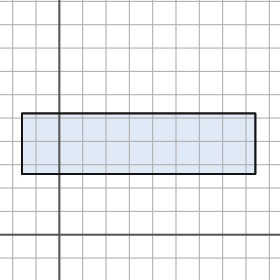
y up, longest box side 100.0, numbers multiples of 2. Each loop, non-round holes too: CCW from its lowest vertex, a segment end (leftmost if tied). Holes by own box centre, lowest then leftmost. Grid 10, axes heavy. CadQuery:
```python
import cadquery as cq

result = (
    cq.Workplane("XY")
    .moveTo(-16.0, 26.0)
    .lineTo(84.0, 26.0)
    .lineTo(84.0, 52.0)
    .lineTo(-16.0, 52.0)
    .close()
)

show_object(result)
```